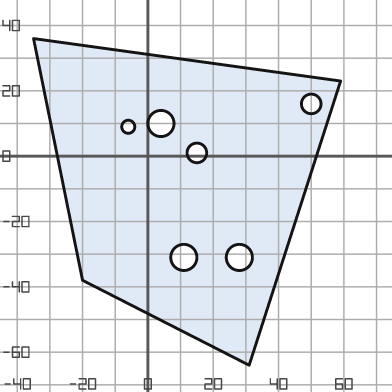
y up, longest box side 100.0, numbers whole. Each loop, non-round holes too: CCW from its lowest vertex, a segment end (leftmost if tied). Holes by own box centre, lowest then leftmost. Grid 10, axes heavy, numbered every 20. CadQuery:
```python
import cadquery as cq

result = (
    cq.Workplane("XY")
    .moveTo(31.0, -64.0)
    .lineTo(59.0, 23.0)
    .lineTo(-35.0, 36.0)
    .lineTo(-20.0, -38.0)
    .close()
    .moveTo(11.0, -31.0)
    .circle(4.0)
    .moveTo(28.0, -31.0)
    .circle(4.0)
    .moveTo(15.0, 1.0)
    .circle(3.0)
    .moveTo(-6.0, 9.0)
    .circle(2.0)
    .moveTo(4.0, 10.0)
    .circle(4.0)
    .moveTo(50.0, 16.0)
    .circle(3.0)
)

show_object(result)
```